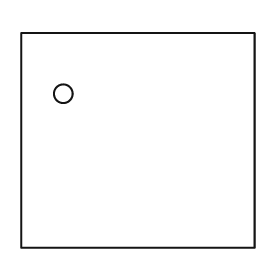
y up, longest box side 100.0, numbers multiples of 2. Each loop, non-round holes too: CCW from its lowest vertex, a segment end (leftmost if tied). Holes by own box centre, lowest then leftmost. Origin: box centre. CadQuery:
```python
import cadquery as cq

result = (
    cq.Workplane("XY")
    .moveTo(-50.0, -46.0)
    .lineTo(50.0, -46.0)
    .lineTo(50.0, 46.0)
    .lineTo(-50.0, 46.0)
    .close()
    .moveTo(-32.0, 20.0)
    .circle(4.0)
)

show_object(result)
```